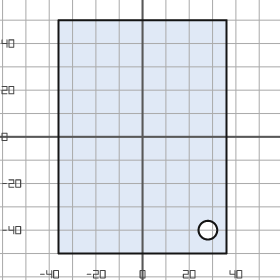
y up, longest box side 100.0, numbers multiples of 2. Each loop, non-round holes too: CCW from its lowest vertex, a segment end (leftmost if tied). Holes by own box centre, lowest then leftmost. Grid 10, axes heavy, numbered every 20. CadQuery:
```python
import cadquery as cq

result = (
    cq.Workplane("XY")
    .moveTo(-36.0, -50.0)
    .lineTo(36.0, -50.0)
    .lineTo(36.0, 50.0)
    .lineTo(-36.0, 50.0)
    .close()
    .moveTo(28.0, -40.0)
    .circle(4.0)
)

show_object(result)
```